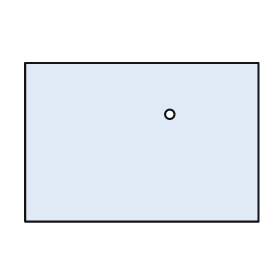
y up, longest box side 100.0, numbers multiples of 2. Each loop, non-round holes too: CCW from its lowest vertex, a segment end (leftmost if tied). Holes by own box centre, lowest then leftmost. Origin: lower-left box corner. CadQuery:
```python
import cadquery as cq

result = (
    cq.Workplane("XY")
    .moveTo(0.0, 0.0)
    .lineTo(100.0, 0.0)
    .lineTo(100.0, 68.0)
    .lineTo(0.0, 68.0)
    .close()
    .moveTo(62.0, 46.0)
    .circle(2.0)
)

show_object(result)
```